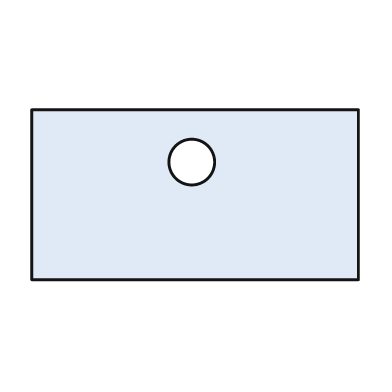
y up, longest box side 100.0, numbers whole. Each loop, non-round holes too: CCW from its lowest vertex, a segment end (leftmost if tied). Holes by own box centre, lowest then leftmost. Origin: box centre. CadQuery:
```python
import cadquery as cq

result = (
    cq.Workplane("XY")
    .moveTo(-50.0, -26.0)
    .lineTo(50.0, -26.0)
    .lineTo(50.0, 26.0)
    .lineTo(-50.0, 26.0)
    .close()
    .moveTo(-1.0, 10.0)
    .circle(7.0)
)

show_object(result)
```